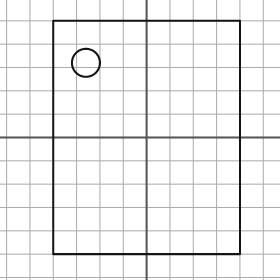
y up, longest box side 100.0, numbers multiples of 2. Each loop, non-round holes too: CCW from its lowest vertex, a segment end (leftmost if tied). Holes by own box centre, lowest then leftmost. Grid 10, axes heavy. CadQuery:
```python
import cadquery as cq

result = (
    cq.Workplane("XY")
    .moveTo(-40.0, -50.0)
    .lineTo(40.0, -50.0)
    .lineTo(40.0, 50.0)
    .lineTo(-40.0, 50.0)
    .close()
    .moveTo(-26.0, 32.0)
    .circle(6.0)
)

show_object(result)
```